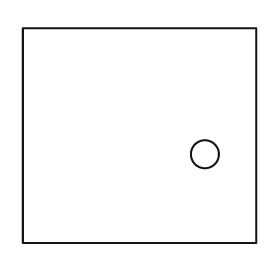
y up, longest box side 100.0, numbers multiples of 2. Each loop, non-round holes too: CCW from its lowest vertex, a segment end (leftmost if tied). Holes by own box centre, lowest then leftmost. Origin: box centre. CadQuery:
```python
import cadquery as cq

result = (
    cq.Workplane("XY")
    .moveTo(-50.0, -46.0)
    .lineTo(50.0, -46.0)
    .lineTo(50.0, 46.0)
    .lineTo(-50.0, 46.0)
    .close()
    .moveTo(28.0, -8.0)
    .circle(6.0)
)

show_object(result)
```